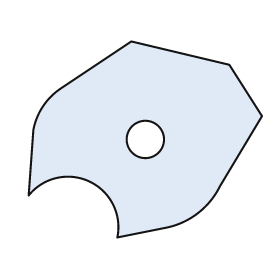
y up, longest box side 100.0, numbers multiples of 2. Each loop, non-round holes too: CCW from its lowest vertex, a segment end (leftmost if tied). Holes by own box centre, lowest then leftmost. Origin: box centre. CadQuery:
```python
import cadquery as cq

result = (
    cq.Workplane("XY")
    .moveTo(-12.0, -42.0)
    .lineTo(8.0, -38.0)
    .threePointArc((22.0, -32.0), (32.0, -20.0))
    .lineTo(50.0, 10.0)
    .lineTo(36.0, 32.0)
    .lineTo(-6.0, 42.0)
    .lineTo(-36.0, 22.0)
    .threePointArc((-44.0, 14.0), (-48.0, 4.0))
    .lineTo(-50.0, -24.0)
    .threePointArc((-24.0, -18.0), (-12.0, -42.0))
    .close()
    .moveTo(0.0, 0.0)
    .circle(8.0)
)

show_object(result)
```